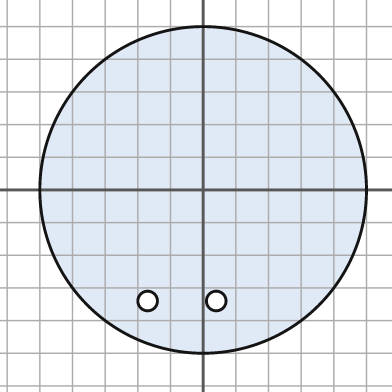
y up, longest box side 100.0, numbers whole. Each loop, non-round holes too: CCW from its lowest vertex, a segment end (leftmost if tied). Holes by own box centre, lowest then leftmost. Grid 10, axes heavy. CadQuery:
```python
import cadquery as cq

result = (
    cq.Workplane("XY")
    .moveTo(0.0, 0.0)
    .circle(50.0)
    .moveTo(-17.0, -34.0)
    .circle(3.0)
    .moveTo(4.0, -34.0)
    .circle(3.0)
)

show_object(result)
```